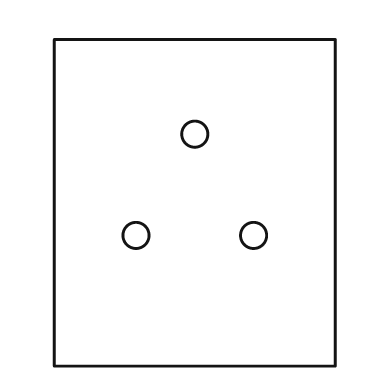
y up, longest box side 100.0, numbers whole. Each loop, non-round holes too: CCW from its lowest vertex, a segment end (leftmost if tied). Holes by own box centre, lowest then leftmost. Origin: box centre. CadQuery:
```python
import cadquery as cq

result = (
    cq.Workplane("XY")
    .moveTo(-43.0, -50.0)
    .lineTo(43.0, -50.0)
    .lineTo(43.0, 50.0)
    .lineTo(-43.0, 50.0)
    .close()
    .moveTo(-18.0, -10.0)
    .circle(4.0)
    .moveTo(18.0, -10.0)
    .circle(4.0)
    .moveTo(0.0, 21.0)
    .circle(4.0)
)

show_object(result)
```